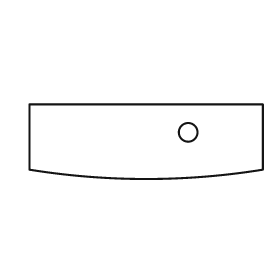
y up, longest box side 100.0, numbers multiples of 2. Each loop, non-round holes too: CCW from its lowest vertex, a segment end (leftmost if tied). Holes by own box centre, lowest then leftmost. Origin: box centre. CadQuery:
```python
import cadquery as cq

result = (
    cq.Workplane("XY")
    .moveTo(-50.0, -12.0)
    .threePointArc((0.0, -16.0), (50.0, -12.0))
    .lineTo(50.0, 16.0)
    .lineTo(-50.0, 16.0)
    .close()
    .moveTo(18.0, 4.0)
    .circle(4.0)
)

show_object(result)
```